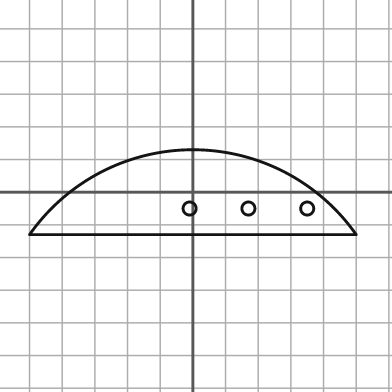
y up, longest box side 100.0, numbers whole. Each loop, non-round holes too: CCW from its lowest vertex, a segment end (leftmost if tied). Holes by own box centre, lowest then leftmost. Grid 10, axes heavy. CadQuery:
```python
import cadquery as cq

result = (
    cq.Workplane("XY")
    .moveTo(-50.0, -13.0)
    .lineTo(50.0, -13.0)
    .threePointArc((0.0, 13.0), (-50.0, -13.0))
    .close()
    .moveTo(-1.0, -5.0)
    .circle(2.0)
    .moveTo(17.0, -5.0)
    .circle(2.0)
    .moveTo(35.0, -5.0)
    .circle(2.0)
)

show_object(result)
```